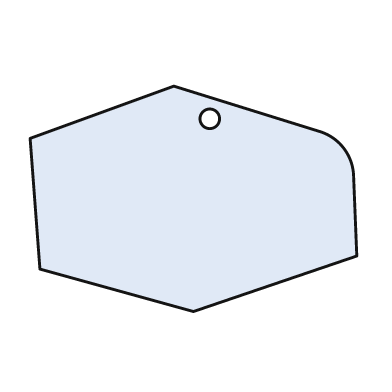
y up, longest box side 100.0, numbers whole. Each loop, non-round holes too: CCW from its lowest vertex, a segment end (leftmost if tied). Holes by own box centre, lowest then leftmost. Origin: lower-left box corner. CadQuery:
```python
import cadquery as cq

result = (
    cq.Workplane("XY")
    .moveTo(50.0, 0.0)
    .lineTo(100.0, 17.0)
    .lineTo(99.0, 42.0)
    .threePointArc((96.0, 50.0), (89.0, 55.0))
    .lineTo(44.0, 69.0)
    .lineTo(0.0, 53.0)
    .lineTo(3.0, 13.0)
    .close()
    .moveTo(55.0, 59.0)
    .circle(3.0)
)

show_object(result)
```